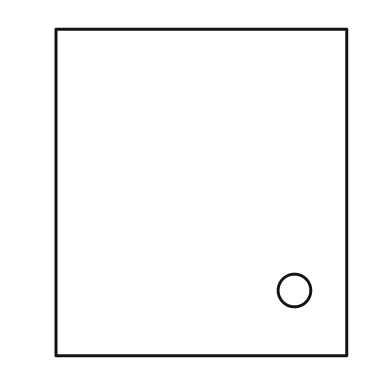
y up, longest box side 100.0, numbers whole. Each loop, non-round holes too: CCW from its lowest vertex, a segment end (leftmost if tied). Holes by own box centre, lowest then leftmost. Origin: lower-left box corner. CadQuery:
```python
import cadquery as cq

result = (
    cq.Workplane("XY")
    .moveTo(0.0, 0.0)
    .lineTo(89.0, 0.0)
    .lineTo(89.0, 100.0)
    .lineTo(0.0, 100.0)
    .close()
    .moveTo(73.0, 20.0)
    .circle(5.0)
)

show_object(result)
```